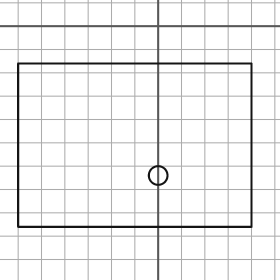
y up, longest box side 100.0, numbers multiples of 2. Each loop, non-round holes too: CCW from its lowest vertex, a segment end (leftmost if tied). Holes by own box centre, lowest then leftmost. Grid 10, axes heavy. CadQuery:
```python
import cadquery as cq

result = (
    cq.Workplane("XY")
    .moveTo(-60.0, -86.0)
    .lineTo(40.0, -86.0)
    .lineTo(40.0, -16.0)
    .lineTo(-60.0, -16.0)
    .close()
    .moveTo(0.0, -64.0)
    .circle(4.0)
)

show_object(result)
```